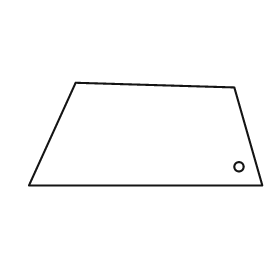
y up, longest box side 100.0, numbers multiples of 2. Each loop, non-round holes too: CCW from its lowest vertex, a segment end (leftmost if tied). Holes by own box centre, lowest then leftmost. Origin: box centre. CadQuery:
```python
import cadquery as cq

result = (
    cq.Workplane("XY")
    .moveTo(-50.0, -22.0)
    .lineTo(50.0, -22.0)
    .lineTo(38.0, 20.0)
    .lineTo(-30.0, 22.0)
    .close()
    .moveTo(40.0, -14.0)
    .circle(2.0)
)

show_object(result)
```